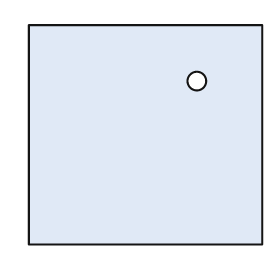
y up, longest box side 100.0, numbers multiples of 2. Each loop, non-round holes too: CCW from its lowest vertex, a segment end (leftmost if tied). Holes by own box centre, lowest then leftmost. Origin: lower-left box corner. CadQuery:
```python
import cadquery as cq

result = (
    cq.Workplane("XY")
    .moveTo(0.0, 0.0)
    .lineTo(100.0, 0.0)
    .lineTo(100.0, 94.0)
    .lineTo(0.0, 94.0)
    .close()
    .moveTo(72.0, 70.0)
    .circle(4.0)
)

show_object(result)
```